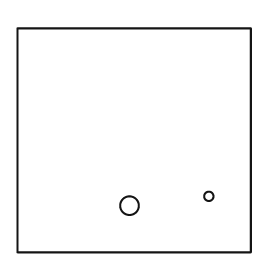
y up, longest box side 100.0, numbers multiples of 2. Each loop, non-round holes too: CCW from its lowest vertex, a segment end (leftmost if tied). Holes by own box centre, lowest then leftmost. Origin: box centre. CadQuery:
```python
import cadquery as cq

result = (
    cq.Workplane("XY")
    .moveTo(-50.0, -48.0)
    .lineTo(50.0, -48.0)
    .lineTo(50.0, 48.0)
    .lineTo(-50.0, 48.0)
    .close()
    .moveTo(-2.0, -28.0)
    .circle(4.0)
    .moveTo(32.0, -24.0)
    .circle(2.0)
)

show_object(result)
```